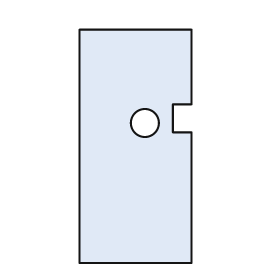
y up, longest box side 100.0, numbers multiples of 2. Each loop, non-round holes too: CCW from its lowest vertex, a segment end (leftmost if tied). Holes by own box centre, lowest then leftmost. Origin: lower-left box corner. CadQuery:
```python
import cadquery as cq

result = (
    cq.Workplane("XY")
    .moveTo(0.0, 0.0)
    .lineTo(48.0, 0.0)
    .lineTo(48.0, 56.0)
    .lineTo(40.0, 56.0)
    .lineTo(40.0, 68.0)
    .lineTo(48.0, 68.0)
    .lineTo(48.0, 100.0)
    .lineTo(0.0, 100.0)
    .close()
    .moveTo(28.0, 60.0)
    .circle(6.0)
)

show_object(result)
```